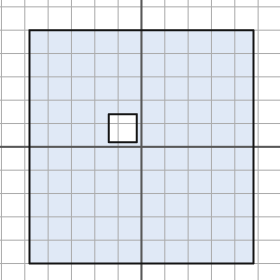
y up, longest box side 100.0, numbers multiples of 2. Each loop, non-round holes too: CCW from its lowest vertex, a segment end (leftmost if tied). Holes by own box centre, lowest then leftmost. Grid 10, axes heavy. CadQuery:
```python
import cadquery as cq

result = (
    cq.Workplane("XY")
    .moveTo(-48.0, -50.0)
    .lineTo(48.0, -50.0)
    .lineTo(48.0, 50.0)
    .lineTo(-48.0, 50.0)
    .close()
    .moveTo(-14.0, 2.0)
    .lineTo(-2.0, 2.0)
    .lineTo(-2.0, 14.0)
    .lineTo(-14.0, 14.0)
    .close()
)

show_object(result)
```